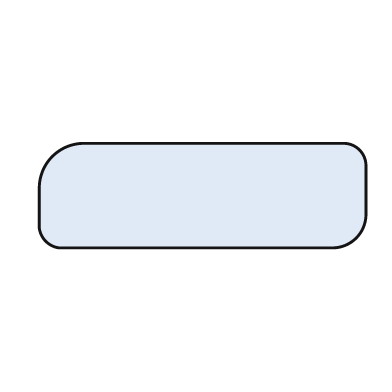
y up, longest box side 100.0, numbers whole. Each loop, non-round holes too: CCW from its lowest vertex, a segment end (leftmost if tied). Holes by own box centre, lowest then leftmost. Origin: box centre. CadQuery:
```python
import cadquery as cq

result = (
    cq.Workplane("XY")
    .moveTo(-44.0, -16.0)
    .lineTo(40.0, -16.0)
    .threePointArc((47.0, -13.0), (50.0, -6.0))
    .lineTo(50.0, 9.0)
    .threePointArc((48.0, 14.0), (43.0, 16.0))
    .lineTo(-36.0, 16.0)
    .threePointArc((-46.0, 12.0), (-50.0, 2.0))
    .lineTo(-50.0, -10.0)
    .threePointArc((-48.0, -14.0), (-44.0, -16.0))
    .close()
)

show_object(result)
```